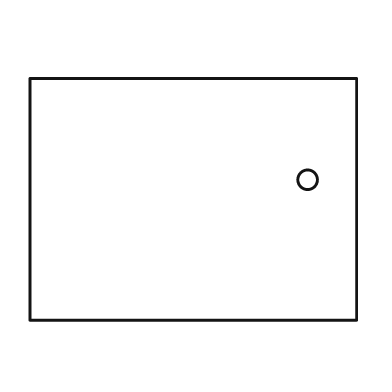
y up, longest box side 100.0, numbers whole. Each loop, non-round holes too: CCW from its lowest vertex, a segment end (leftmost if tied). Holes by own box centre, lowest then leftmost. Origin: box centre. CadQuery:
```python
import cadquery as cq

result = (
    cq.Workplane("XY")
    .moveTo(-50.0, -37.0)
    .lineTo(50.0, -37.0)
    .lineTo(50.0, 37.0)
    .lineTo(-50.0, 37.0)
    .close()
    .moveTo(35.0, 6.0)
    .circle(3.0)
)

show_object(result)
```